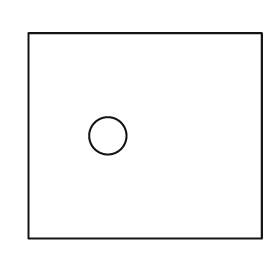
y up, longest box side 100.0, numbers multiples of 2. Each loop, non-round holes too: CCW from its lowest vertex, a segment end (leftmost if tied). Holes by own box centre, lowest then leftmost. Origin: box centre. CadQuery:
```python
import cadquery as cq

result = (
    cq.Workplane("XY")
    .moveTo(-50.0, -44.0)
    .lineTo(50.0, -44.0)
    .lineTo(50.0, 44.0)
    .lineTo(-50.0, 44.0)
    .close()
    .moveTo(-16.0, 0.0)
    .circle(8.0)
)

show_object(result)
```